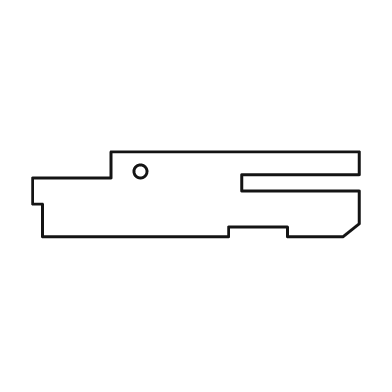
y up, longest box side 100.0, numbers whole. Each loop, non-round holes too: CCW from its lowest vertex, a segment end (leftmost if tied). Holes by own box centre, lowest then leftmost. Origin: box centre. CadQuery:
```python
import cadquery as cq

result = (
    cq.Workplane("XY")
    .moveTo(-47.0, -13.0)
    .lineTo(10.0, -13.0)
    .lineTo(10.0, -10.0)
    .lineTo(28.0, -10.0)
    .lineTo(28.0, -13.0)
    .lineTo(45.0, -13.0)
    .lineTo(50.0, -9.0)
    .lineTo(50.0, 1.0)
    .lineTo(14.0, 1.0)
    .lineTo(14.0, 6.0)
    .lineTo(50.0, 6.0)
    .lineTo(50.0, 13.0)
    .lineTo(-26.0, 13.0)
    .lineTo(-26.0, 5.0)
    .lineTo(-50.0, 5.0)
    .lineTo(-50.0, -3.0)
    .lineTo(-47.0, -3.0)
    .close()
    .moveTo(-17.0, 7.0)
    .circle(2.0)
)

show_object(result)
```